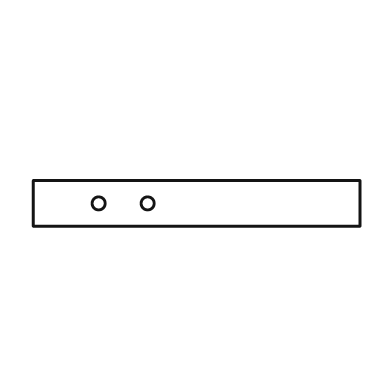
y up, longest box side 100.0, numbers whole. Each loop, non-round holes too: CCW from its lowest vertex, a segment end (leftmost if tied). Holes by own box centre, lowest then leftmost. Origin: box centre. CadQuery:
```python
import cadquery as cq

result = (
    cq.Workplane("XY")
    .moveTo(-50.0, -7.0)
    .lineTo(50.0, -7.0)
    .lineTo(50.0, 7.0)
    .lineTo(-50.0, 7.0)
    .close()
    .moveTo(-30.0, 0.0)
    .circle(2.0)
    .moveTo(-15.0, 0.0)
    .circle(2.0)
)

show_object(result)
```